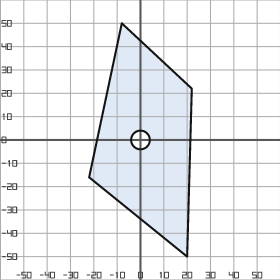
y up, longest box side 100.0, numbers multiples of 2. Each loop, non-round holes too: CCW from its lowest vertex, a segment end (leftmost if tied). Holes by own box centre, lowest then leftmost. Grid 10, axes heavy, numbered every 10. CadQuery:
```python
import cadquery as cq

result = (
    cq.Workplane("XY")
    .moveTo(20.0, -50.0)
    .lineTo(22.0, 22.0)
    .lineTo(-8.0, 50.0)
    .lineTo(-22.0, -16.0)
    .close()
    .moveTo(0.0, 0.0)
    .circle(4.0)
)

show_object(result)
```